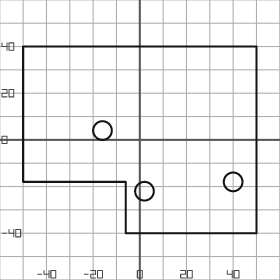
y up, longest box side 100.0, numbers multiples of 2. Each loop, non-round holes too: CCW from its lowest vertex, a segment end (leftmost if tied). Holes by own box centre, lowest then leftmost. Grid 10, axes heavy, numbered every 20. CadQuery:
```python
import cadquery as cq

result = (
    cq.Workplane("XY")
    .moveTo(-6.0, -40.0)
    .lineTo(50.0, -40.0)
    .lineTo(50.0, 40.0)
    .lineTo(-50.0, 40.0)
    .lineTo(-50.0, -18.0)
    .lineTo(-6.0, -18.0)
    .close()
    .moveTo(2.0, -22.0)
    .circle(4.0)
    .moveTo(40.0, -18.0)
    .circle(4.0)
    .moveTo(-16.0, 4.0)
    .circle(4.0)
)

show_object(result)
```